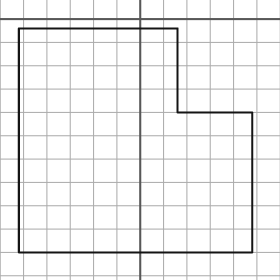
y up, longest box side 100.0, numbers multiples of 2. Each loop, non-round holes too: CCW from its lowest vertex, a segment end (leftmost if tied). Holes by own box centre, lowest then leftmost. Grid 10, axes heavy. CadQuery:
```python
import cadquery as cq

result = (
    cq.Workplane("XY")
    .moveTo(-52.0, -100.0)
    .lineTo(48.0, -100.0)
    .lineTo(48.0, -40.0)
    .lineTo(16.0, -40.0)
    .lineTo(16.0, -4.0)
    .lineTo(-52.0, -4.0)
    .close()
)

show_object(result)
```